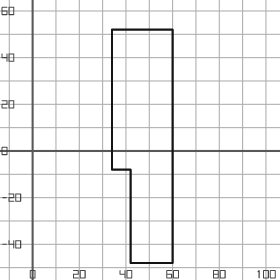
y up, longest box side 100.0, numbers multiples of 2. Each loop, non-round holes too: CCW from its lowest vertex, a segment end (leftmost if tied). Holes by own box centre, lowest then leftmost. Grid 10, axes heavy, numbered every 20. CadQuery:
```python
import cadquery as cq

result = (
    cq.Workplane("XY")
    .moveTo(42.0, -48.0)
    .lineTo(60.0, -48.0)
    .lineTo(60.0, 52.0)
    .lineTo(34.0, 52.0)
    .lineTo(34.0, -8.0)
    .lineTo(42.0, -8.0)
    .close()
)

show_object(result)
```